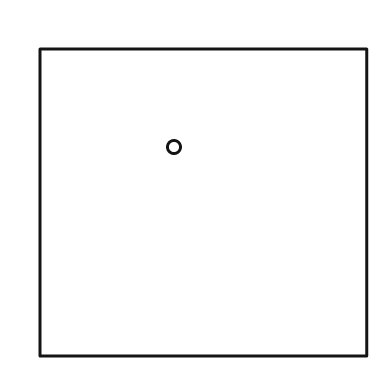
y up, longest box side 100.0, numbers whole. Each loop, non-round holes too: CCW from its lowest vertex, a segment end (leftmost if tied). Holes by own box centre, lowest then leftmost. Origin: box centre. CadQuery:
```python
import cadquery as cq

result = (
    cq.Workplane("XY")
    .moveTo(-50.0, -47.0)
    .lineTo(50.0, -47.0)
    .lineTo(50.0, 47.0)
    .lineTo(-50.0, 47.0)
    .close()
    .moveTo(-9.0, 17.0)
    .circle(2.0)
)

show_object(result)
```